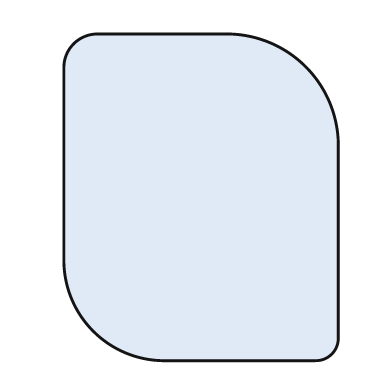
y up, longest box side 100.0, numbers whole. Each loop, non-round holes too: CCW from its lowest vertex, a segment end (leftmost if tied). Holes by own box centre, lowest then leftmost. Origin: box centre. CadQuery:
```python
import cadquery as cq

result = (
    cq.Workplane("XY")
    .moveTo(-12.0, -50.0)
    .lineTo(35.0, -50.0)
    .threePointArc((40.0, -48.0), (42.0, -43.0))
    .lineTo(42.0, 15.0)
    .threePointArc((32.0, 40.0), (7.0, 50.0))
    .lineTo(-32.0, 50.0)
    .threePointArc((-39.0, 47.0), (-42.0, 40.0))
    .lineTo(-42.0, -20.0)
    .threePointArc((-33.0, -41.0), (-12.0, -50.0))
    .close()
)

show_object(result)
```